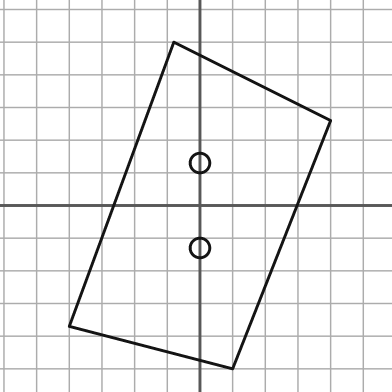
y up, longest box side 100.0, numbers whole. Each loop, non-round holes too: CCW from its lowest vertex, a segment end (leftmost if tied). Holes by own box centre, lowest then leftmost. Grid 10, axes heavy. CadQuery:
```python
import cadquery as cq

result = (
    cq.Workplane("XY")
    .moveTo(10.0, -50.0)
    .lineTo(40.0, 26.0)
    .lineTo(-8.0, 50.0)
    .lineTo(-40.0, -37.0)
    .close()
    .moveTo(0.0, -13.0)
    .circle(3.0)
    .moveTo(0.0, 13.0)
    .circle(3.0)
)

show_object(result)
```